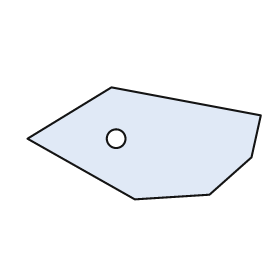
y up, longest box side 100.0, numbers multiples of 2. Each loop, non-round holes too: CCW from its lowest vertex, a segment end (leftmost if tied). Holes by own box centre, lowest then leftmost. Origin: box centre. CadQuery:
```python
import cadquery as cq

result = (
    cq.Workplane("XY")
    .moveTo(-4.0, -24.0)
    .lineTo(28.0, -22.0)
    .lineTo(46.0, -6.0)
    .lineTo(50.0, 12.0)
    .lineTo(-14.0, 24.0)
    .lineTo(-50.0, 2.0)
    .close()
    .moveTo(-12.0, 2.0)
    .circle(4.0)
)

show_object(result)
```